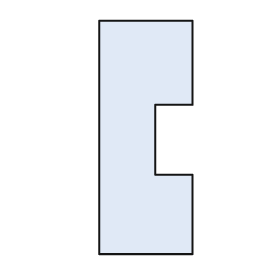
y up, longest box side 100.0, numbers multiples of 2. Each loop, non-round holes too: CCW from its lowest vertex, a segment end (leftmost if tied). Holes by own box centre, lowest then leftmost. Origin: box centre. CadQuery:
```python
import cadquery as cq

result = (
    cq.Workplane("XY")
    .moveTo(-20.0, -50.0)
    .lineTo(20.0, -50.0)
    .lineTo(20.0, -16.0)
    .lineTo(4.0, -16.0)
    .lineTo(4.0, 14.0)
    .lineTo(20.0, 14.0)
    .lineTo(20.0, 50.0)
    .lineTo(-20.0, 50.0)
    .close()
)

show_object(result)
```